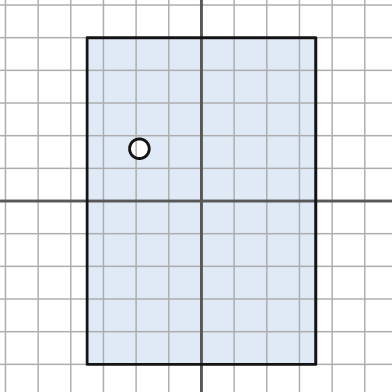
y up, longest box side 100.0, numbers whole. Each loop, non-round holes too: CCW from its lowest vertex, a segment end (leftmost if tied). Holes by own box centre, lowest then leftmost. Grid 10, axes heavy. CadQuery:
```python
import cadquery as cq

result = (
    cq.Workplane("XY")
    .moveTo(-35.0, -50.0)
    .lineTo(35.0, -50.0)
    .lineTo(35.0, 50.0)
    .lineTo(-35.0, 50.0)
    .close()
    .moveTo(-19.0, 16.0)
    .circle(3.0)
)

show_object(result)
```